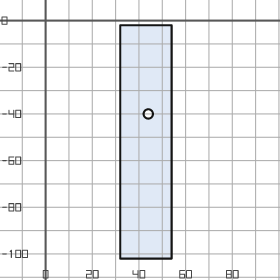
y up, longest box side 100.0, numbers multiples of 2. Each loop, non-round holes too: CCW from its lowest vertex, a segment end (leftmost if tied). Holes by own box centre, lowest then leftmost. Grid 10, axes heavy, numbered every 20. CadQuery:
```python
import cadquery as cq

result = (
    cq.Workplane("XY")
    .moveTo(32.0, -102.0)
    .lineTo(54.0, -102.0)
    .lineTo(54.0, -2.0)
    .lineTo(32.0, -2.0)
    .close()
    .moveTo(44.0, -40.0)
    .circle(2.0)
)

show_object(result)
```